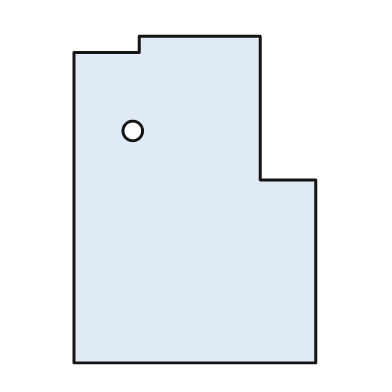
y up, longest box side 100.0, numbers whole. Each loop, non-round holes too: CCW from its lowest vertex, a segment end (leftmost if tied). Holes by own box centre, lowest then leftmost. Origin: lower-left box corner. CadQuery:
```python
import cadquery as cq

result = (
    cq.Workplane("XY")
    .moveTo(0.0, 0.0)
    .lineTo(74.0, 0.0)
    .lineTo(74.0, 56.0)
    .lineTo(57.0, 56.0)
    .lineTo(57.0, 100.0)
    .lineTo(20.0, 100.0)
    .lineTo(20.0, 95.0)
    .lineTo(0.0, 95.0)
    .close()
    .moveTo(18.0, 71.0)
    .circle(3.0)
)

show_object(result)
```